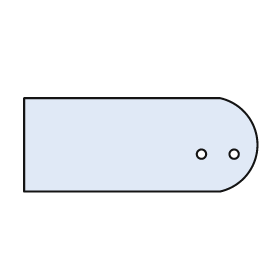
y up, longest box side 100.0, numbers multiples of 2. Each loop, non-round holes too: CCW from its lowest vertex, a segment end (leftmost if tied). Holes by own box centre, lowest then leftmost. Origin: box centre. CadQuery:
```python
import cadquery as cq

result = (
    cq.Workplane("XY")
    .moveTo(-50.0, -20.0)
    .lineTo(34.0, -20.0)
    .threePointArc((50.0, 0.0), (34.0, 20.0))
    .lineTo(-50.0, 20.0)
    .close()
    .moveTo(26.0, -4.0)
    .circle(2.0)
    .moveTo(40.0, -4.0)
    .circle(2.0)
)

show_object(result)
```